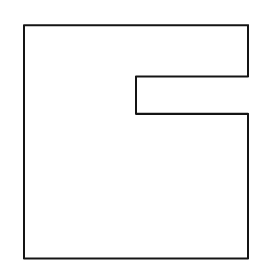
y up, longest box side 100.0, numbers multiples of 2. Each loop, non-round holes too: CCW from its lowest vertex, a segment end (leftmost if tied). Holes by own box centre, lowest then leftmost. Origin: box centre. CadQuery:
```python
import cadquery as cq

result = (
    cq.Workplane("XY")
    .moveTo(-48.0, -50.0)
    .lineTo(48.0, -50.0)
    .lineTo(48.0, 12.0)
    .lineTo(0.0, 12.0)
    .lineTo(0.0, 28.0)
    .lineTo(48.0, 28.0)
    .lineTo(48.0, 50.0)
    .lineTo(-48.0, 50.0)
    .close()
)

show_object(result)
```